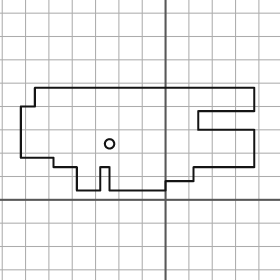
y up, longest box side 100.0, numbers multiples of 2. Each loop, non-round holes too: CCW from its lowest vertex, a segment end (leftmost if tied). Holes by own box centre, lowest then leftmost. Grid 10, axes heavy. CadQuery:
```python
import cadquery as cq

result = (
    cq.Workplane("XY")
    .moveTo(-38.0, 4.0)
    .lineTo(-28.0, 4.0)
    .lineTo(-28.0, 14.0)
    .lineTo(-24.0, 14.0)
    .lineTo(-24.0, 4.0)
    .lineTo(0.0, 4.0)
    .lineTo(0.0, 8.0)
    .lineTo(12.0, 8.0)
    .lineTo(12.0, 14.0)
    .lineTo(38.0, 14.0)
    .lineTo(38.0, 30.0)
    .lineTo(14.0, 30.0)
    .lineTo(14.0, 38.0)
    .lineTo(38.0, 38.0)
    .lineTo(38.0, 48.0)
    .lineTo(-56.0, 48.0)
    .lineTo(-56.0, 40.0)
    .lineTo(-62.0, 40.0)
    .lineTo(-62.0, 18.0)
    .lineTo(-48.0, 18.0)
    .lineTo(-48.0, 14.0)
    .lineTo(-38.0, 14.0)
    .close()
    .moveTo(-24.0, 24.0)
    .circle(2.0)
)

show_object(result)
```